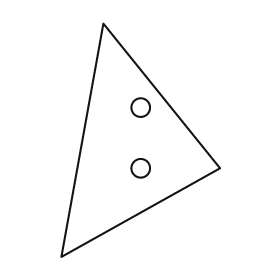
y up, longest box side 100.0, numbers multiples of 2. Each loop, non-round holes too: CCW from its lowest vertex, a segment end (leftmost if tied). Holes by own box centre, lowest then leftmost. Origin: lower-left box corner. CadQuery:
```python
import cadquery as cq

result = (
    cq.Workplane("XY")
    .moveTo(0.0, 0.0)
    .lineTo(68.0, 38.0)
    .lineTo(18.0, 100.0)
    .close()
    .moveTo(34.0, 38.0)
    .circle(4.0)
    .moveTo(34.0, 64.0)
    .circle(4.0)
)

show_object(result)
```